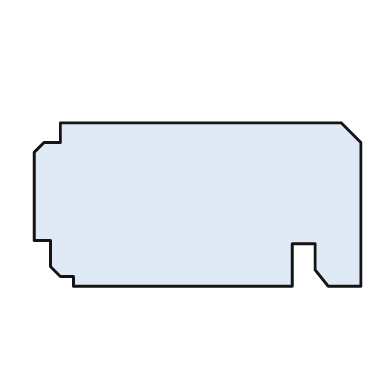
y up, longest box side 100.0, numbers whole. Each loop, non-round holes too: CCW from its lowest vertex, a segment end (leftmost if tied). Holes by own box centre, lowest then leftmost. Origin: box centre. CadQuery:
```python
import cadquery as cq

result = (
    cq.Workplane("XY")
    .moveTo(-38.0, -25.0)
    .lineTo(29.0, -25.0)
    .lineTo(29.0, -12.0)
    .lineTo(36.0, -12.0)
    .lineTo(36.0, -20.0)
    .lineTo(40.0, -25.0)
    .lineTo(50.0, -25.0)
    .lineTo(50.0, 19.0)
    .lineTo(44.0, 25.0)
    .lineTo(-42.0, 25.0)
    .lineTo(-42.0, 19.0)
    .lineTo(-47.0, 19.0)
    .lineTo(-50.0, 16.0)
    .lineTo(-50.0, -11.0)
    .lineTo(-45.0, -11.0)
    .lineTo(-45.0, -19.0)
    .lineTo(-42.0, -22.0)
    .lineTo(-38.0, -22.0)
    .close()
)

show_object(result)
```